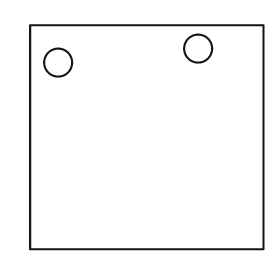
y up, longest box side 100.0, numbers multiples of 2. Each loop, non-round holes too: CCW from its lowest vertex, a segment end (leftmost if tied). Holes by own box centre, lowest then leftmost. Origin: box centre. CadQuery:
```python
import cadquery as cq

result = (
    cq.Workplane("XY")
    .moveTo(-50.0, -48.0)
    .lineTo(50.0, -48.0)
    .lineTo(50.0, 48.0)
    .lineTo(-50.0, 48.0)
    .close()
    .moveTo(-38.0, 32.0)
    .circle(6.0)
    .moveTo(22.0, 38.0)
    .circle(6.0)
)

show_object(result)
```